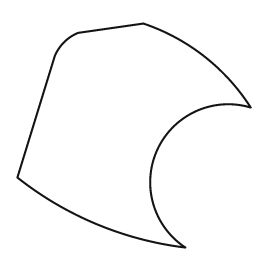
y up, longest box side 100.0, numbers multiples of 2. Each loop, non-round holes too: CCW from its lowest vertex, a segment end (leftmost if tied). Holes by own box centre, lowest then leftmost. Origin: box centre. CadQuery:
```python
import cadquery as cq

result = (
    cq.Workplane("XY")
    .moveTo(22.0, -48.0)
    .threePointArc((10.0, -6.0), (50.0, 12.0))
    .threePointArc((30.0, 34.0), (4.0, 48.0))
    .lineTo(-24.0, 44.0)
    .threePointArc((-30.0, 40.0), (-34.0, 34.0))
    .lineTo(-50.0, -18.0)
    .threePointArc((-16.0, -38.0), (22.0, -48.0))
    .close()
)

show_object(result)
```